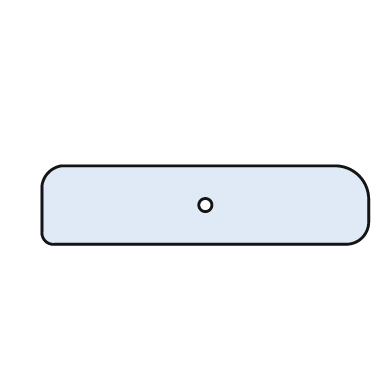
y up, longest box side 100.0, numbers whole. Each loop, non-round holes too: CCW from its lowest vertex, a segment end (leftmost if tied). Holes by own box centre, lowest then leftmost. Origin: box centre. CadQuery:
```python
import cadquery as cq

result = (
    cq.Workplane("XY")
    .moveTo(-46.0, -12.0)
    .lineTo(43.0, -12.0)
    .threePointArc((48.0, -10.0), (50.0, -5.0))
    .lineTo(50.0, 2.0)
    .threePointArc((47.0, 9.0), (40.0, 12.0))
    .lineTo(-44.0, 12.0)
    .threePointArc((-48.0, 10.0), (-50.0, 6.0))
    .lineTo(-50.0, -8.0)
    .threePointArc((-49.0, -11.0), (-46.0, -12.0))
    .close()
    .moveTo(0.0, 0.0)
    .circle(2.0)
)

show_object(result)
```